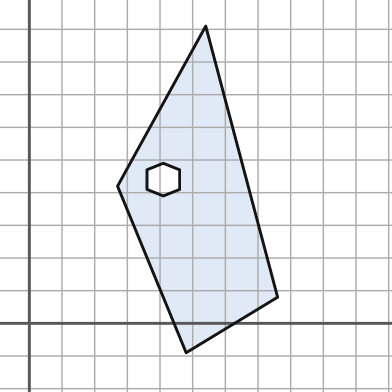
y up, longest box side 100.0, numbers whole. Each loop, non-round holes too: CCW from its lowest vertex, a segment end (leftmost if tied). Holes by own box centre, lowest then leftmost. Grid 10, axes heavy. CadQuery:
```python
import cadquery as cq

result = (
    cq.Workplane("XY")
    .moveTo(48.0, -9.0)
    .lineTo(76.0, 8.0)
    .lineTo(54.0, 91.0)
    .lineTo(27.0, 42.0)
    .close()
    .moveTo(41.0, 39.0)
    .lineTo(46.0, 41.0)
    .lineTo(46.0, 47.0)
    .lineTo(41.0, 49.0)
    .lineTo(36.0, 47.0)
    .lineTo(36.0, 41.0)
    .close()
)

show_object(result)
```